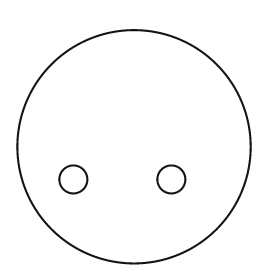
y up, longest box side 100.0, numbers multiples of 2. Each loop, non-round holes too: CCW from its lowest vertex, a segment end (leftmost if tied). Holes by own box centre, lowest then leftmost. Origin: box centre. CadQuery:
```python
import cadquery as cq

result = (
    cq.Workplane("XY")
    .moveTo(0.0, 0.0)
    .circle(50.0)
    .moveTo(-26.0, -14.0)
    .circle(6.0)
    .moveTo(16.0, -14.0)
    .circle(6.0)
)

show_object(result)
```